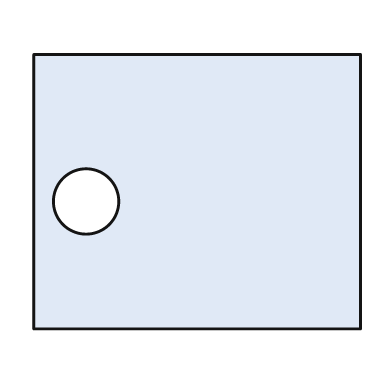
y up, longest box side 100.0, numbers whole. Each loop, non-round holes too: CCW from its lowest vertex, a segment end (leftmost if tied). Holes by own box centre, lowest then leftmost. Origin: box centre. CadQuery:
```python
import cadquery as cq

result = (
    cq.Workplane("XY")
    .moveTo(-50.0, -42.0)
    .lineTo(50.0, -42.0)
    .lineTo(50.0, 42.0)
    .lineTo(-50.0, 42.0)
    .close()
    .moveTo(-34.0, -3.0)
    .circle(10.0)
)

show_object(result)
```